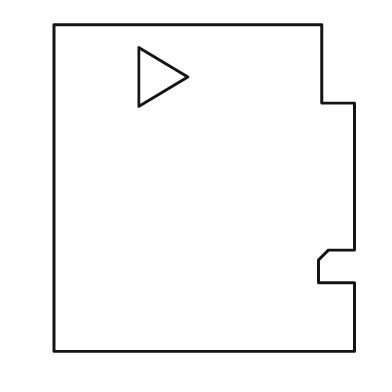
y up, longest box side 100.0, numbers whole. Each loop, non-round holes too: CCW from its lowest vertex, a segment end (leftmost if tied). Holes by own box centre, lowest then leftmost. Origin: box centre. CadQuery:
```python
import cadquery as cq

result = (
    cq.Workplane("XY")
    .moveTo(-46.0, -50.0)
    .lineTo(46.0, -50.0)
    .lineTo(46.0, -29.0)
    .lineTo(35.0, -29.0)
    .lineTo(35.0, -22.0)
    .lineTo(38.0, -19.0)
    .lineTo(46.0, -19.0)
    .lineTo(46.0, 26.0)
    .lineTo(36.0, 26.0)
    .lineTo(36.0, 50.0)
    .lineTo(-46.0, 50.0)
    .close()
    .moveTo(-20.0, 25.0)
    .lineTo(-5.0, 34.0)
    .lineTo(-20.0, 43.0)
    .close()
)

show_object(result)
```